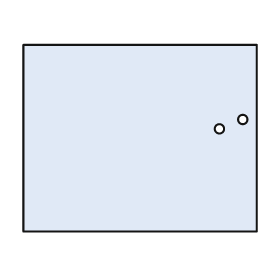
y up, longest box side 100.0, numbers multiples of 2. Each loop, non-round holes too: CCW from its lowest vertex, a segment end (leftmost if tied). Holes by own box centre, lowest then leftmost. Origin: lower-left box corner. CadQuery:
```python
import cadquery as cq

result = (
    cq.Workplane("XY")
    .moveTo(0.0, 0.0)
    .lineTo(100.0, 0.0)
    .lineTo(100.0, 80.0)
    .lineTo(0.0, 80.0)
    .close()
    .moveTo(84.0, 44.0)
    .circle(2.0)
    .moveTo(94.0, 48.0)
    .circle(2.0)
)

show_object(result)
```